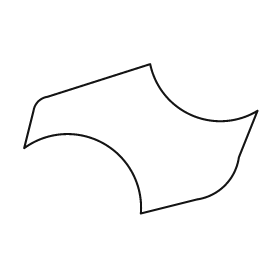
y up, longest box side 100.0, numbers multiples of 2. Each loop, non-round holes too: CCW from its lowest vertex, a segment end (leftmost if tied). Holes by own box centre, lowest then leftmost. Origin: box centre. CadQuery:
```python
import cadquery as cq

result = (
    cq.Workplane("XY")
    .moveTo(0.0, -32.0)
    .lineTo(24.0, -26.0)
    .threePointArc((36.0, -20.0), (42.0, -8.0))
    .lineTo(50.0, 12.0)
    .threePointArc((22.0, 10.0), (4.0, 32.0))
    .lineTo(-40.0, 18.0)
    .threePointArc((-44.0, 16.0), (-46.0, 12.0))
    .lineTo(-50.0, -4.0)
    .threePointArc((-16.0, -2.0), (0.0, -32.0))
    .close()
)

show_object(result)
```